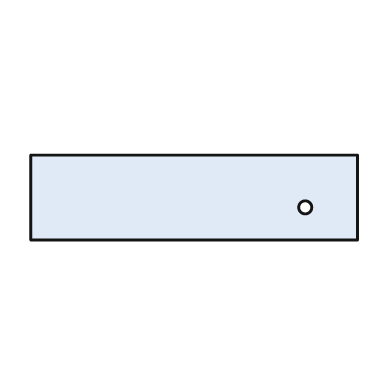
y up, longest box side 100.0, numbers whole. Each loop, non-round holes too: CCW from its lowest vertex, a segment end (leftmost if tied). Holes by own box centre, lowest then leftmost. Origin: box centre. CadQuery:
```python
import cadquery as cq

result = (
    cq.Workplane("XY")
    .moveTo(-50.0, -13.0)
    .lineTo(50.0, -13.0)
    .lineTo(50.0, 13.0)
    .lineTo(-50.0, 13.0)
    .close()
    .moveTo(34.0, -3.0)
    .circle(2.0)
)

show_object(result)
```